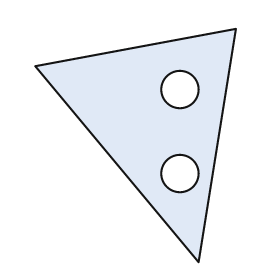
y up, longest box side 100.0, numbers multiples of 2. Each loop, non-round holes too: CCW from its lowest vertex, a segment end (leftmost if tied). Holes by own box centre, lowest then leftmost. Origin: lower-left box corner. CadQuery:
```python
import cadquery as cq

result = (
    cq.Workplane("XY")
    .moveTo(70.0, 0.0)
    .lineTo(86.0, 100.0)
    .lineTo(0.0, 84.0)
    .close()
    .moveTo(62.0, 38.0)
    .circle(8.0)
    .moveTo(62.0, 74.0)
    .circle(8.0)
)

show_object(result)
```